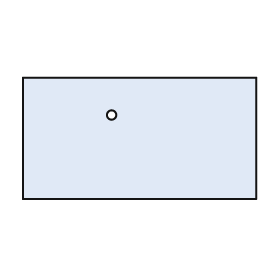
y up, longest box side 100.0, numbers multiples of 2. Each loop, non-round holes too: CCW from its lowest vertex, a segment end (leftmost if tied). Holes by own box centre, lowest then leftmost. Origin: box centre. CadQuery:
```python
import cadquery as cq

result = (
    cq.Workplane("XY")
    .moveTo(-50.0, -26.0)
    .lineTo(50.0, -26.0)
    .lineTo(50.0, 26.0)
    .lineTo(-50.0, 26.0)
    .close()
    .moveTo(-12.0, 10.0)
    .circle(2.0)
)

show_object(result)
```